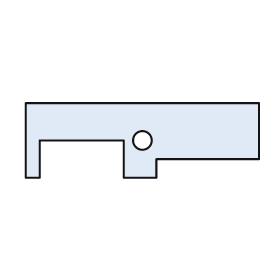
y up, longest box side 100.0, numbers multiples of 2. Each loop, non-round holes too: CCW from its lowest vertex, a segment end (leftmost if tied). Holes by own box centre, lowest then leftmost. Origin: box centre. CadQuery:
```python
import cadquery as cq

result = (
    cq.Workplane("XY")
    .moveTo(-50.0, -16.0)
    .lineTo(-44.0, -16.0)
    .lineTo(-44.0, 0.0)
    .lineTo(-8.0, 0.0)
    .lineTo(-8.0, -16.0)
    .lineTo(6.0, -16.0)
    .lineTo(6.0, -8.0)
    .lineTo(50.0, -8.0)
    .lineTo(50.0, 16.0)
    .lineTo(-50.0, 16.0)
    .close()
    .moveTo(0.0, 0.0)
    .circle(4.0)
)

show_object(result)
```